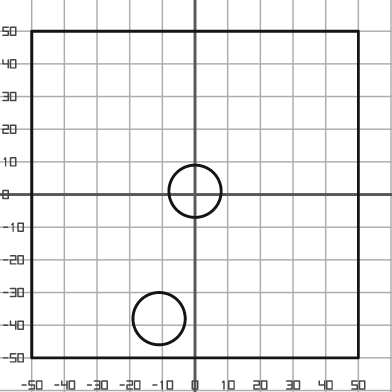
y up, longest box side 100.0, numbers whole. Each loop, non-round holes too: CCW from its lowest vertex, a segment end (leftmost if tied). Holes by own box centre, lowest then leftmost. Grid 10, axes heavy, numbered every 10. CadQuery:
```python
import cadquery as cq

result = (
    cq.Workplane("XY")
    .moveTo(-50.0, -50.0)
    .lineTo(50.0, -50.0)
    .lineTo(50.0, 50.0)
    .lineTo(-50.0, 50.0)
    .close()
    .moveTo(-11.0, -38.0)
    .circle(8.0)
    .moveTo(0.0, 1.0)
    .circle(8.0)
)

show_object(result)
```